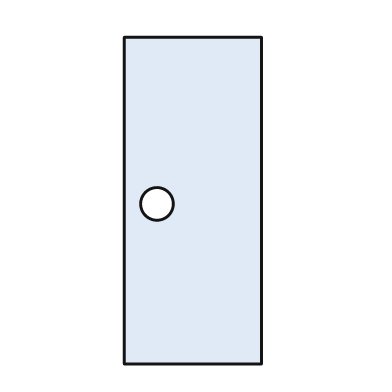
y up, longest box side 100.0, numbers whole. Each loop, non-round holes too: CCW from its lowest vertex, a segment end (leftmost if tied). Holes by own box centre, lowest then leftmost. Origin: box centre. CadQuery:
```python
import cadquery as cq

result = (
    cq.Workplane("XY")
    .moveTo(-21.0, -50.0)
    .lineTo(21.0, -50.0)
    .lineTo(21.0, 50.0)
    .lineTo(-21.0, 50.0)
    .close()
    .moveTo(-11.0, -1.0)
    .circle(5.0)
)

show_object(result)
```